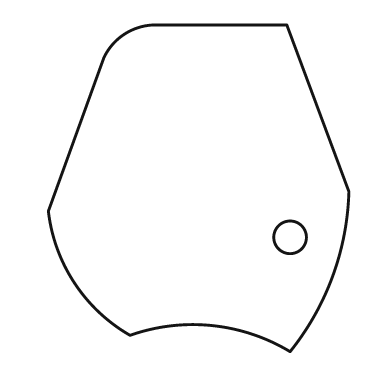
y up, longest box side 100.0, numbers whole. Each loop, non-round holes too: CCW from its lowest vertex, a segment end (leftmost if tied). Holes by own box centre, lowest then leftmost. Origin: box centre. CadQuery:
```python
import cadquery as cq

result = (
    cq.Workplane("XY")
    .moveTo(28.0, -50.0)
    .threePointArc((41.0, -27.0), (46.0, -1.0))
    .lineTo(27.0, 50.0)
    .lineTo(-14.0, 50.0)
    .threePointArc((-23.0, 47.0), (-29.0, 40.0))
    .lineTo(-46.0, -7.0)
    .threePointArc((-38.0, -29.0), (-21.0, -45.0))
    .threePointArc((4.0, -42.0), (28.0, -50.0))
    .close()
    .moveTo(28.0, -15.0)
    .circle(5.0)
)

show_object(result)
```